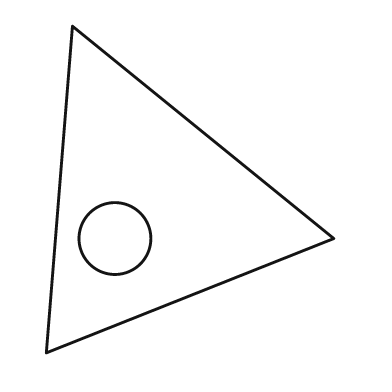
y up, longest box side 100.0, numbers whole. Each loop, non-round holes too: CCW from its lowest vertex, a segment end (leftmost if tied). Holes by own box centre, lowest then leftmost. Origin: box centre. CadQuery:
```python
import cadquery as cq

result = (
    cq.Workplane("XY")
    .moveTo(-44.0, -50.0)
    .lineTo(44.0, -15.0)
    .lineTo(-36.0, 50.0)
    .close()
    .moveTo(-23.0, -15.0)
    .circle(11.0)
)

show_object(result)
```